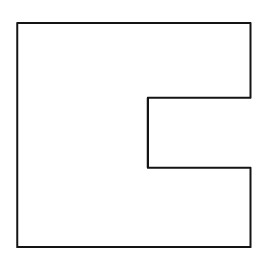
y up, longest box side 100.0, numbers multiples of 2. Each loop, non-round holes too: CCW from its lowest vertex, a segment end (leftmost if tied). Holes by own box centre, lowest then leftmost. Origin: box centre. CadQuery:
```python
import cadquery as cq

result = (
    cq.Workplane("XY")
    .moveTo(-50.0, -48.0)
    .lineTo(50.0, -48.0)
    .lineTo(50.0, -14.0)
    .lineTo(6.0, -14.0)
    .lineTo(6.0, 16.0)
    .lineTo(50.0, 16.0)
    .lineTo(50.0, 48.0)
    .lineTo(-50.0, 48.0)
    .close()
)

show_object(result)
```